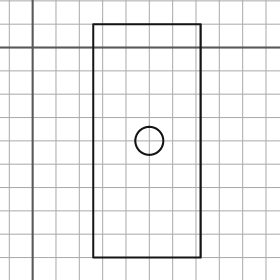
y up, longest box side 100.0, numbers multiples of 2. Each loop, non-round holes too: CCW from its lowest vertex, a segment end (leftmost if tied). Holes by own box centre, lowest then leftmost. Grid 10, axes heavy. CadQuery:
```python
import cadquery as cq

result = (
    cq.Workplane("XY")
    .moveTo(26.0, -90.0)
    .lineTo(72.0, -90.0)
    .lineTo(72.0, 10.0)
    .lineTo(26.0, 10.0)
    .close()
    .moveTo(50.0, -40.0)
    .circle(6.0)
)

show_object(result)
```